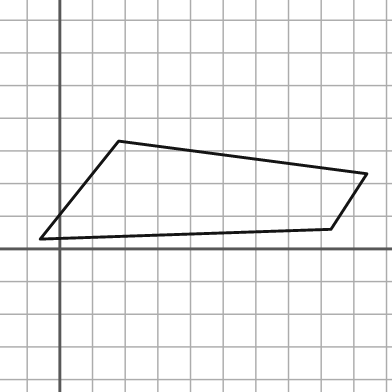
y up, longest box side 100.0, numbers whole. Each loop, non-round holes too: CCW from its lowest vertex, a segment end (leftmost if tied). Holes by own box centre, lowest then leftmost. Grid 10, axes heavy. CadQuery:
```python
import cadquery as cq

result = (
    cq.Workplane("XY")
    .moveTo(-6.0, 3.0)
    .lineTo(83.0, 6.0)
    .lineTo(94.0, 23.0)
    .lineTo(18.0, 33.0)
    .close()
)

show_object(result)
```